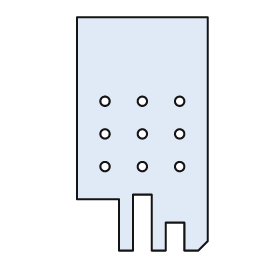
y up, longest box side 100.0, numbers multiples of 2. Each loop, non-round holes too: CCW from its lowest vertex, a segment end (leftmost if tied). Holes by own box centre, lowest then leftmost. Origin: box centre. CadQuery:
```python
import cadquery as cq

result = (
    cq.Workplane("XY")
    .moveTo(-10.0, -50.0)
    .lineTo(-4.0, -50.0)
    .lineTo(-4.0, -26.0)
    .lineTo(4.0, -26.0)
    .lineTo(4.0, -50.0)
    .lineTo(10.0, -50.0)
    .lineTo(10.0, -38.0)
    .lineTo(18.0, -38.0)
    .lineTo(18.0, -50.0)
    .lineTo(24.0, -50.0)
    .lineTo(28.0, -46.0)
    .lineTo(28.0, 50.0)
    .lineTo(-28.0, 50.0)
    .lineTo(-28.0, -28.0)
    .lineTo(-10.0, -28.0)
    .close()
    .moveTo(-16.0, -14.0)
    .circle(2.0)
    .moveTo(0.0, -14.0)
    .circle(2.0)
    .moveTo(16.0, -14.0)
    .circle(2.0)
    .moveTo(-16.0, 0.0)
    .circle(2.0)
    .moveTo(0.0, 0.0)
    .circle(2.0)
    .moveTo(16.0, 0.0)
    .circle(2.0)
    .moveTo(-16.0, 14.0)
    .circle(2.0)
    .moveTo(0.0, 14.0)
    .circle(2.0)
    .moveTo(16.0, 14.0)
    .circle(2.0)
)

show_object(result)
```